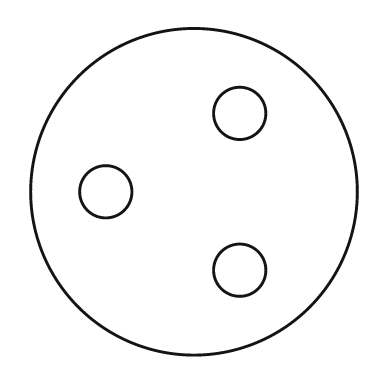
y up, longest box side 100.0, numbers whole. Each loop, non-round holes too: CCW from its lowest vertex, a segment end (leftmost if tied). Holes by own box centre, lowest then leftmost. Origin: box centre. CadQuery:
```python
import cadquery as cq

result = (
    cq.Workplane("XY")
    .moveTo(0.0, 0.0)
    .circle(50.0)
    .moveTo(14.0, -24.0)
    .circle(8.0)
    .moveTo(-27.0, 0.0)
    .circle(8.0)
    .moveTo(14.0, 24.0)
    .circle(8.0)
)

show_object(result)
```